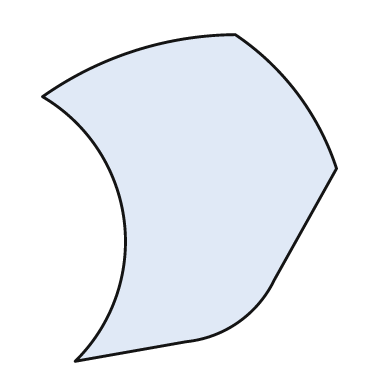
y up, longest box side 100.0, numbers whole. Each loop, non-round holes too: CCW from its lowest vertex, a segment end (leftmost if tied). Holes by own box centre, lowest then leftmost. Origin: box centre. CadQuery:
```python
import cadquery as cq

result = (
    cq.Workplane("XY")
    .moveTo(-35.0, -50.0)
    .lineTo(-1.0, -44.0)
    .threePointArc((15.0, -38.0), (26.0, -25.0))
    .lineTo(45.0, 9.0)
    .threePointArc((33.0, 32.0), (14.0, 50.0))
    .threePointArc((-17.0, 45.0), (-45.0, 31.0))
    .threePointArc((-20.0, -7.0), (-35.0, -50.0))
    .close()
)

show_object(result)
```